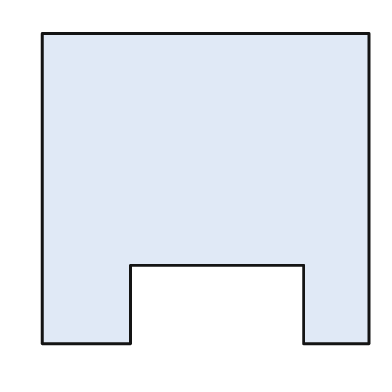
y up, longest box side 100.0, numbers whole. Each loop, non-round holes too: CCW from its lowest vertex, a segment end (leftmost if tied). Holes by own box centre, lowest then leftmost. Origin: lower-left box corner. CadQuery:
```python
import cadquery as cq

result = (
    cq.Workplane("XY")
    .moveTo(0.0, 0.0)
    .lineTo(27.0, 0.0)
    .lineTo(27.0, 24.0)
    .lineTo(80.0, 24.0)
    .lineTo(80.0, 0.0)
    .lineTo(100.0, 0.0)
    .lineTo(100.0, 95.0)
    .lineTo(0.0, 95.0)
    .close()
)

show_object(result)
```